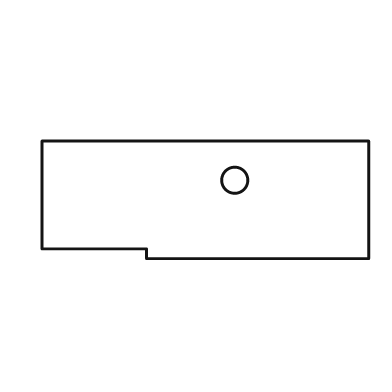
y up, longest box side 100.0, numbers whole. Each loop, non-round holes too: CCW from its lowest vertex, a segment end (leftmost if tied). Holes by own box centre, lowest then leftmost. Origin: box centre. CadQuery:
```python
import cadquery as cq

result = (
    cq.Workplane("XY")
    .moveTo(-18.0, -18.0)
    .lineTo(50.0, -18.0)
    .lineTo(50.0, 18.0)
    .lineTo(-50.0, 18.0)
    .lineTo(-50.0, -15.0)
    .lineTo(-18.0, -15.0)
    .close()
    .moveTo(9.0, 6.0)
    .circle(4.0)
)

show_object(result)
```